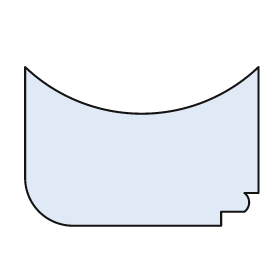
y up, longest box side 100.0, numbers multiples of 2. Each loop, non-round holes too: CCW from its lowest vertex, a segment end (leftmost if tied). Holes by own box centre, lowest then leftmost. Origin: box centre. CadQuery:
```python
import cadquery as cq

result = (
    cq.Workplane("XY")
    .moveTo(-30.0, -34.0)
    .lineTo(34.0, -34.0)
    .lineTo(34.0, -28.0)
    .lineTo(44.0, -28.0)
    .threePointArc((46.0, -24.0), (44.0, -20.0))
    .lineTo(50.0, -20.0)
    .lineTo(50.0, 34.0)
    .threePointArc((0.0, 14.0), (-50.0, 34.0))
    .lineTo(-50.0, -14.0)
    .threePointArc((-44.0, -28.0), (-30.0, -34.0))
    .close()
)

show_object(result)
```